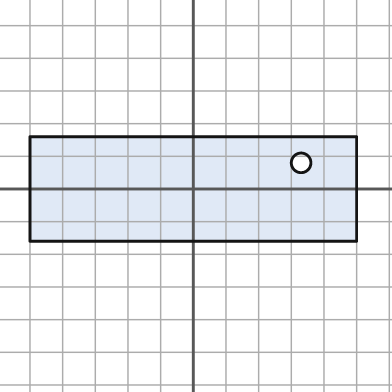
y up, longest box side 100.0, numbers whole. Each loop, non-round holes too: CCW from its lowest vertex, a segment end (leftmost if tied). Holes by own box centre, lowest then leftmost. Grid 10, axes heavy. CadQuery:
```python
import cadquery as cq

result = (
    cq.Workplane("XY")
    .moveTo(-50.0, -16.0)
    .lineTo(50.0, -16.0)
    .lineTo(50.0, 16.0)
    .lineTo(-50.0, 16.0)
    .close()
    .moveTo(33.0, 8.0)
    .circle(3.0)
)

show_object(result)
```